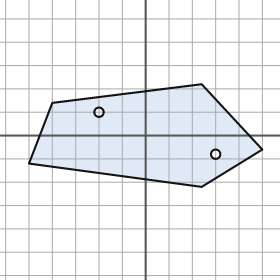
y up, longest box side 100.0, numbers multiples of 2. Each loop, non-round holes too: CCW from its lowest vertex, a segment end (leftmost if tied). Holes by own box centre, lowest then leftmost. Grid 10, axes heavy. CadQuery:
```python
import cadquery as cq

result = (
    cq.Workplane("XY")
    .moveTo(24.0, -22.0)
    .lineTo(50.0, -6.0)
    .lineTo(24.0, 22.0)
    .lineTo(-40.0, 14.0)
    .lineTo(-50.0, -12.0)
    .close()
    .moveTo(30.0, -8.0)
    .circle(2.0)
    .moveTo(-20.0, 10.0)
    .circle(2.0)
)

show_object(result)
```